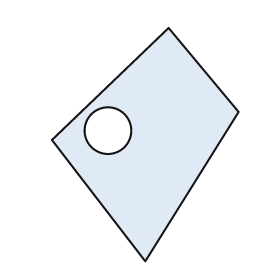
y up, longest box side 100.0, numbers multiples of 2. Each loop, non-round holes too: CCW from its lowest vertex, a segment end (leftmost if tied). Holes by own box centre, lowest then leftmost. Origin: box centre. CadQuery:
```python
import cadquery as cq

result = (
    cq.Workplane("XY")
    .moveTo(0.0, -50.0)
    .lineTo(40.0, 14.0)
    .lineTo(10.0, 50.0)
    .lineTo(-40.0, 2.0)
    .close()
    .moveTo(-16.0, 6.0)
    .circle(10.0)
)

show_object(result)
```